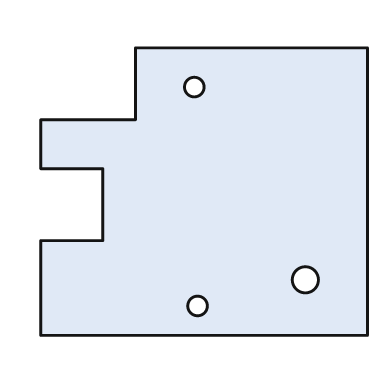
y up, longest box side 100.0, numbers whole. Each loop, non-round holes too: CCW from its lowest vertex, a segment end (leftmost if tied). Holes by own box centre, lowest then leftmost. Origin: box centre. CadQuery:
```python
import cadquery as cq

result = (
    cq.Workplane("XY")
    .moveTo(-50.0, -44.0)
    .lineTo(50.0, -44.0)
    .lineTo(50.0, 44.0)
    .lineTo(-21.0, 44.0)
    .lineTo(-21.0, 22.0)
    .lineTo(-50.0, 22.0)
    .lineTo(-50.0, 7.0)
    .lineTo(-31.0, 7.0)
    .lineTo(-31.0, -15.0)
    .lineTo(-50.0, -15.0)
    .close()
    .moveTo(-2.0, -35.0)
    .circle(3.0)
    .moveTo(31.0, -27.0)
    .circle(4.0)
    .moveTo(-3.0, 32.0)
    .circle(3.0)
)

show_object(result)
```